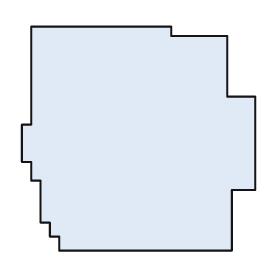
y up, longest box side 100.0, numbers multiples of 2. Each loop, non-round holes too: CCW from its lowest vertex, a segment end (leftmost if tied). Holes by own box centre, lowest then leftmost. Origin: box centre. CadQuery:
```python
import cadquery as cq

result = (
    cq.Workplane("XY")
    .moveTo(-34.0, -48.0)
    .lineTo(40.0, -48.0)
    .lineTo(40.0, -22.0)
    .lineTo(50.0, -22.0)
    .lineTo(50.0, 18.0)
    .lineTo(38.0, 18.0)
    .lineTo(38.0, 44.0)
    .lineTo(14.0, 44.0)
    .lineTo(14.0, 48.0)
    .lineTo(-46.0, 48.0)
    .lineTo(-46.0, 6.0)
    .lineTo(-50.0, 6.0)
    .lineTo(-50.0, -10.0)
    .lineTo(-46.0, -10.0)
    .lineTo(-46.0, -18.0)
    .lineTo(-42.0, -18.0)
    .lineTo(-42.0, -36.0)
    .lineTo(-38.0, -36.0)
    .lineTo(-38.0, -42.0)
    .lineTo(-34.0, -42.0)
    .close()
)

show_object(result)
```